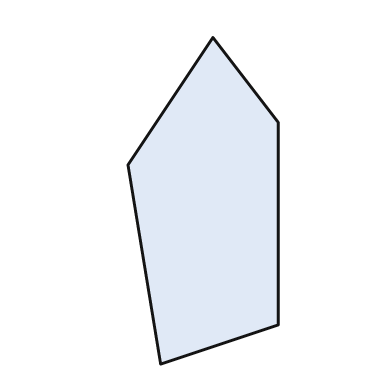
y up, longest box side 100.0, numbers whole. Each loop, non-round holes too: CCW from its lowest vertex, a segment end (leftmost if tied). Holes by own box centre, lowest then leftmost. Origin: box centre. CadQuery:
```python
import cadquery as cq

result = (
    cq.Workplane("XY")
    .moveTo(-13.0, -50.0)
    .lineTo(23.0, -38.0)
    .lineTo(23.0, 24.0)
    .lineTo(3.0, 50.0)
    .lineTo(-23.0, 11.0)
    .close()
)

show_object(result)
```